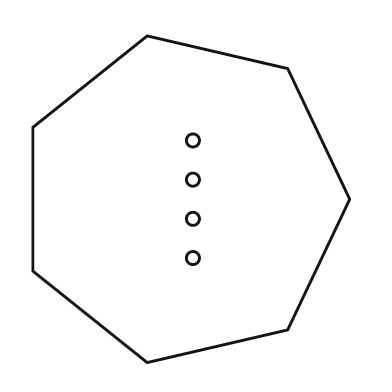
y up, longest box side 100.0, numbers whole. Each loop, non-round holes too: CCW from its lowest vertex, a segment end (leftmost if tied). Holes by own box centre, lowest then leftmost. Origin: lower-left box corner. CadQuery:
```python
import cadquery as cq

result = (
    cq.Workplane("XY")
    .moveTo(35.0, 0.0)
    .lineTo(78.0, 10.0)
    .lineTo(97.0, 50.0)
    .lineTo(78.0, 90.0)
    .lineTo(35.0, 100.0)
    .lineTo(0.0, 72.0)
    .lineTo(0.0, 28.0)
    .close()
    .moveTo(49.0, 32.0)
    .circle(2.0)
    .moveTo(49.0, 44.0)
    .circle(2.0)
    .moveTo(49.0, 56.0)
    .circle(2.0)
    .moveTo(49.0, 68.0)
    .circle(2.0)
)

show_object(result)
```